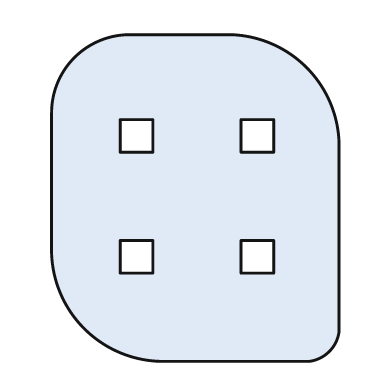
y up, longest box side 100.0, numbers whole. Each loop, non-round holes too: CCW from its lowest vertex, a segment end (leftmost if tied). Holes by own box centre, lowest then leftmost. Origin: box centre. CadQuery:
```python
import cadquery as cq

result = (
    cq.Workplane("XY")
    .moveTo(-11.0, -50.0)
    .lineTo(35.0, -50.0)
    .threePointArc((41.0, -47.0), (44.0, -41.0))
    .lineTo(44.0, 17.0)
    .threePointArc((34.0, 40.0), (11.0, 50.0))
    .lineTo(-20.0, 50.0)
    .threePointArc((-37.0, 43.0), (-44.0, 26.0))
    .lineTo(-44.0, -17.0)
    .threePointArc((-34.0, -40.0), (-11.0, -50.0))
    .close()
    .moveTo(-23.0, -23.0)
    .lineTo(-13.0, -23.0)
    .lineTo(-13.0, -13.0)
    .lineTo(-23.0, -13.0)
    .close()
    .moveTo(14.0, -23.0)
    .lineTo(24.0, -23.0)
    .lineTo(24.0, -13.0)
    .lineTo(14.0, -13.0)
    .close()
    .moveTo(-23.0, 14.0)
    .lineTo(-13.0, 14.0)
    .lineTo(-13.0, 24.0)
    .lineTo(-23.0, 24.0)
    .close()
    .moveTo(14.0, 14.0)
    .lineTo(24.0, 14.0)
    .lineTo(24.0, 24.0)
    .lineTo(14.0, 24.0)
    .close()
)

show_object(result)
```